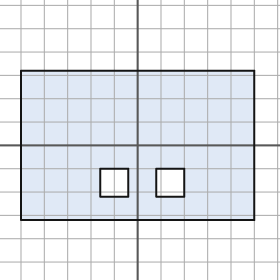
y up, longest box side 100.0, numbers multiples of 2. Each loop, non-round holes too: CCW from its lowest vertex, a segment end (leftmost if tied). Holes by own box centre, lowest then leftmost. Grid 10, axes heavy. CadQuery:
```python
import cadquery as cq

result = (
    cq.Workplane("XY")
    .moveTo(-50.0, -32.0)
    .lineTo(50.0, -32.0)
    .lineTo(50.0, 32.0)
    .lineTo(-50.0, 32.0)
    .close()
    .moveTo(-16.0, -22.0)
    .lineTo(-4.0, -22.0)
    .lineTo(-4.0, -10.0)
    .lineTo(-16.0, -10.0)
    .close()
    .moveTo(8.0, -22.0)
    .lineTo(20.0, -22.0)
    .lineTo(20.0, -10.0)
    .lineTo(8.0, -10.0)
    .close()
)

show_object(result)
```